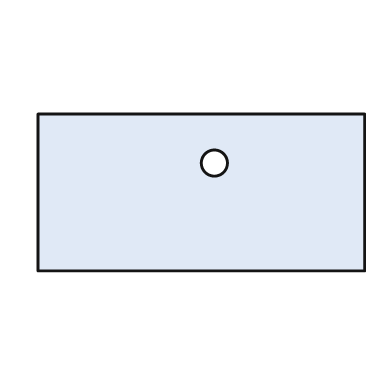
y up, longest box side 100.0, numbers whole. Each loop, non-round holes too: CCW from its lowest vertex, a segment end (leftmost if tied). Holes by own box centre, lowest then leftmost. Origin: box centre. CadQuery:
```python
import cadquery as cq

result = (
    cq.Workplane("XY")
    .moveTo(-50.0, -24.0)
    .lineTo(50.0, -24.0)
    .lineTo(50.0, 24.0)
    .lineTo(-50.0, 24.0)
    .close()
    .moveTo(4.0, 9.0)
    .circle(4.0)
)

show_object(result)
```